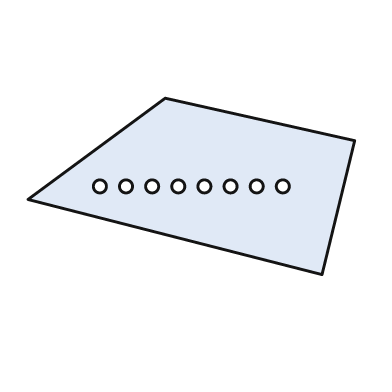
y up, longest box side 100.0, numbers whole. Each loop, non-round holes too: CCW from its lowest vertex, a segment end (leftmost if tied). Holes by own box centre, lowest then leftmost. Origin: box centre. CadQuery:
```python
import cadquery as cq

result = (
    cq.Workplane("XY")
    .moveTo(40.0, -27.0)
    .lineTo(50.0, 14.0)
    .lineTo(-8.0, 27.0)
    .lineTo(-50.0, -4.0)
    .close()
    .moveTo(-28.0, 0.0)
    .circle(2.0)
    .moveTo(-20.0, 0.0)
    .circle(2.0)
    .moveTo(-12.0, 0.0)
    .circle(2.0)
    .moveTo(-4.0, 0.0)
    .circle(2.0)
    .moveTo(4.0, 0.0)
    .circle(2.0)
    .moveTo(12.0, 0.0)
    .circle(2.0)
    .moveTo(20.0, 0.0)
    .circle(2.0)
    .moveTo(28.0, 0.0)
    .circle(2.0)
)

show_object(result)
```